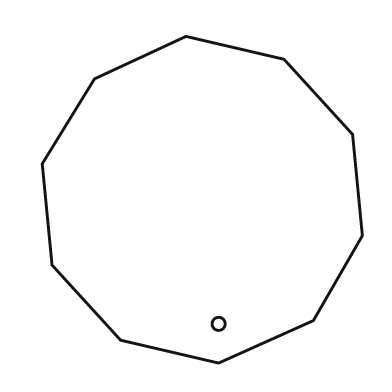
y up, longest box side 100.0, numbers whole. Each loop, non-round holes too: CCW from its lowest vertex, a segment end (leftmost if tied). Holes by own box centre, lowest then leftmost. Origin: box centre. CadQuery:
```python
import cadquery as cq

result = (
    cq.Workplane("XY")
    .moveTo(5.0, -50.0)
    .lineTo(34.0, -37.0)
    .lineTo(49.0, -11.0)
    .lineTo(46.0, 20.0)
    .lineTo(25.0, 43.0)
    .lineTo(-5.0, 50.0)
    .lineTo(-33.0, 37.0)
    .lineTo(-49.0, 11.0)
    .lineTo(-46.0, -20.0)
    .lineTo(-25.0, -43.0)
    .close()
    .moveTo(5.0, -38.0)
    .circle(2.0)
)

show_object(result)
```